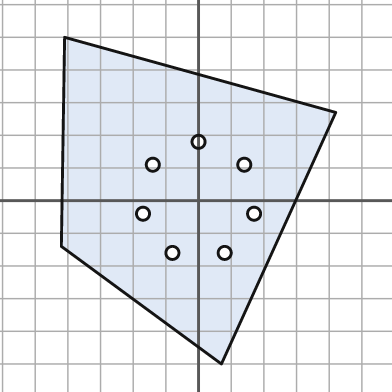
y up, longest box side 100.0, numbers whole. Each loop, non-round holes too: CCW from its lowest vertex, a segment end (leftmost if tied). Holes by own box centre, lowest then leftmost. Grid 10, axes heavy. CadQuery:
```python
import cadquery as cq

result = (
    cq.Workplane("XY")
    .moveTo(7.0, -50.0)
    .lineTo(42.0, 27.0)
    .lineTo(-41.0, 50.0)
    .lineTo(-42.0, -14.0)
    .close()
    .moveTo(-8.0, -16.0)
    .circle(2.0)
    .moveTo(8.0, -16.0)
    .circle(2.0)
    .moveTo(-17.0, -4.0)
    .circle(2.0)
    .moveTo(17.0, -4.0)
    .circle(2.0)
    .moveTo(-14.0, 11.0)
    .circle(2.0)
    .moveTo(14.0, 11.0)
    .circle(2.0)
    .moveTo(0.0, 18.0)
    .circle(2.0)
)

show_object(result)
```